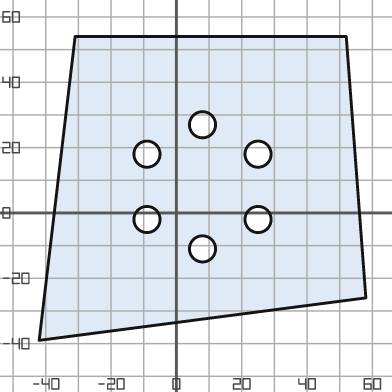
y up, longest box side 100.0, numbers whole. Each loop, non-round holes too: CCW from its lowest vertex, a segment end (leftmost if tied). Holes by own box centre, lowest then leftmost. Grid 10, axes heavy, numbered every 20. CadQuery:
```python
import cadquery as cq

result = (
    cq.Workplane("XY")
    .moveTo(-42.0, -39.0)
    .lineTo(58.0, -26.0)
    .lineTo(52.0, 54.0)
    .lineTo(-31.0, 54.0)
    .close()
    .moveTo(8.0, -11.0)
    .circle(4.0)
    .moveTo(-9.0, -2.0)
    .circle(4.0)
    .moveTo(25.0, -2.0)
    .circle(4.0)
    .moveTo(-9.0, 18.0)
    .circle(4.0)
    .moveTo(25.0, 18.0)
    .circle(4.0)
    .moveTo(8.0, 27.0)
    .circle(4.0)
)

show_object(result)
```